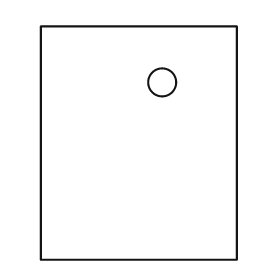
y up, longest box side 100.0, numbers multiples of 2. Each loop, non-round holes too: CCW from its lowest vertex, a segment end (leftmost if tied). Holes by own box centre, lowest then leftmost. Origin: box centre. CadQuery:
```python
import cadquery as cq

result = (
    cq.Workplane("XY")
    .moveTo(-42.0, -50.0)
    .lineTo(42.0, -50.0)
    .lineTo(42.0, 50.0)
    .lineTo(-42.0, 50.0)
    .close()
    .moveTo(10.0, 26.0)
    .circle(6.0)
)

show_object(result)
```